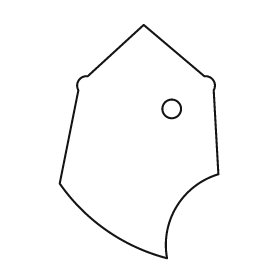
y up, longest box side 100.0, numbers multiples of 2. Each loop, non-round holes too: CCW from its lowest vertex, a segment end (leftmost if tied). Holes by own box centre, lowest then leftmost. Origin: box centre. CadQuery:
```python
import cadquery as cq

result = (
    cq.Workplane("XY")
    .moveTo(12.0, -50.0)
    .threePointArc((16.0, -28.0), (34.0, -14.0))
    .lineTo(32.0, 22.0)
    .threePointArc((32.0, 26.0), (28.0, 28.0))
    .lineTo(2.0, 50.0)
    .lineTo(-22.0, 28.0)
    .threePointArc((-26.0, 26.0), (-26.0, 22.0))
    .lineTo(-34.0, -18.0)
    .threePointArc((-14.0, -38.0), (12.0, -50.0))
    .close()
    .moveTo(14.0, 14.0)
    .circle(4.0)
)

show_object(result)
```